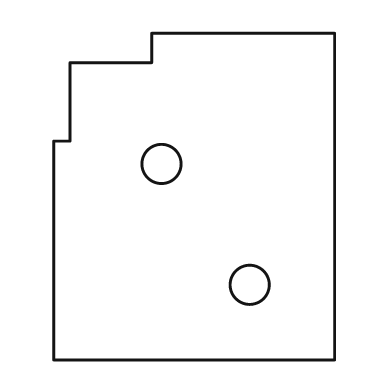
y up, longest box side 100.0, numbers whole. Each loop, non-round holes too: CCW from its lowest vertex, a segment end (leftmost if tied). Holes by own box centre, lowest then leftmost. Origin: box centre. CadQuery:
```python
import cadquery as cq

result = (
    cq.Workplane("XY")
    .moveTo(-43.0, -50.0)
    .lineTo(43.0, -50.0)
    .lineTo(43.0, 50.0)
    .lineTo(-13.0, 50.0)
    .lineTo(-13.0, 41.0)
    .lineTo(-38.0, 41.0)
    .lineTo(-38.0, 17.0)
    .lineTo(-43.0, 17.0)
    .close()
    .moveTo(17.0, -27.0)
    .circle(6.0)
    .moveTo(-10.0, 10.0)
    .circle(6.0)
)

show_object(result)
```